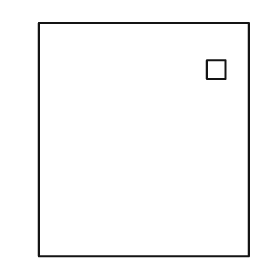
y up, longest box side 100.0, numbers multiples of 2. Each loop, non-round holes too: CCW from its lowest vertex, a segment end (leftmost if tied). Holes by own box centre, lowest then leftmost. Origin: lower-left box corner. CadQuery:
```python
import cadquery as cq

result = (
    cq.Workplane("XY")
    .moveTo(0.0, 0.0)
    .lineTo(90.0, 0.0)
    .lineTo(90.0, 100.0)
    .lineTo(0.0, 100.0)
    .close()
    .moveTo(72.0, 76.0)
    .lineTo(80.0, 76.0)
    .lineTo(80.0, 84.0)
    .lineTo(72.0, 84.0)
    .close()
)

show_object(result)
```